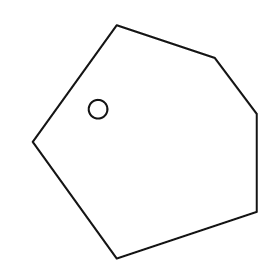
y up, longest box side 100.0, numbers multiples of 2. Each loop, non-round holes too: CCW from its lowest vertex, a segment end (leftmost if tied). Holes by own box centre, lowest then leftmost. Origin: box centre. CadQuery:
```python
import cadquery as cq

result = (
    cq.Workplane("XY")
    .moveTo(-12.0, -50.0)
    .lineTo(48.0, -30.0)
    .lineTo(48.0, 12.0)
    .lineTo(30.0, 36.0)
    .lineTo(-12.0, 50.0)
    .lineTo(-48.0, 0.0)
    .close()
    .moveTo(-20.0, 14.0)
    .circle(4.0)
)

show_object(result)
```